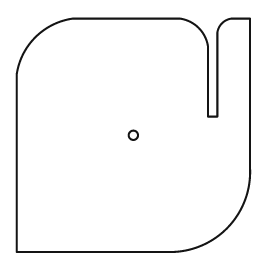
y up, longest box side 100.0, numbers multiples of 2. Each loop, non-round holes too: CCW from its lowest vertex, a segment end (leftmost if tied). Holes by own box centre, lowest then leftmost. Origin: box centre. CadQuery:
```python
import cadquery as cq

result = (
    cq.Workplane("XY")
    .moveTo(-50.0, -50.0)
    .lineTo(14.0, -50.0)
    .threePointArc((40.0, -40.0), (50.0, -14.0))
    .lineTo(50.0, 50.0)
    .lineTo(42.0, 50.0)
    .threePointArc((38.0, 48.0), (36.0, 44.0))
    .lineTo(36.0, 8.0)
    .lineTo(32.0, 8.0)
    .lineTo(32.0, 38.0)
    .threePointArc((28.0, 46.0), (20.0, 50.0))
    .lineTo(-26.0, 50.0)
    .threePointArc((-42.0, 42.0), (-50.0, 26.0))
    .close()
    .moveTo(0.0, 0.0)
    .circle(2.0)
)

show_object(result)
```